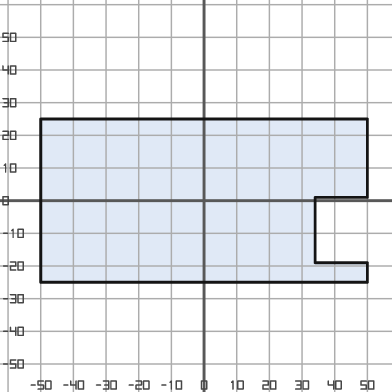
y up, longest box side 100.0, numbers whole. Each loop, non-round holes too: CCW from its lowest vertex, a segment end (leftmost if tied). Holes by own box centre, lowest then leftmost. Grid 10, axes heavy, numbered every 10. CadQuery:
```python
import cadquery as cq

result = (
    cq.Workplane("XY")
    .moveTo(-50.0, -25.0)
    .lineTo(50.0, -25.0)
    .lineTo(50.0, -19.0)
    .lineTo(34.0, -19.0)
    .lineTo(34.0, 1.0)
    .lineTo(50.0, 1.0)
    .lineTo(50.0, 25.0)
    .lineTo(-50.0, 25.0)
    .close()
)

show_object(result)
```